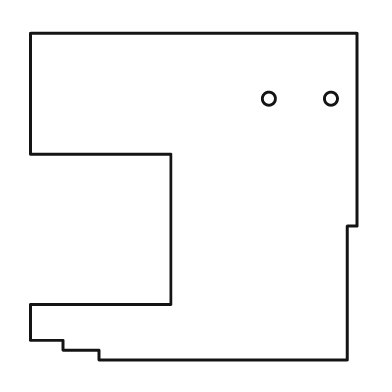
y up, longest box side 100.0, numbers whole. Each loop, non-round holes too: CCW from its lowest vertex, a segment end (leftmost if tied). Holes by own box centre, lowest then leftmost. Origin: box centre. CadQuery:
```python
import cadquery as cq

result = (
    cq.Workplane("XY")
    .moveTo(-29.0, -50.0)
    .lineTo(47.0, -50.0)
    .lineTo(47.0, -9.0)
    .lineTo(50.0, -9.0)
    .lineTo(50.0, 50.0)
    .lineTo(-50.0, 50.0)
    .lineTo(-50.0, 13.0)
    .lineTo(-7.0, 13.0)
    .lineTo(-7.0, -33.0)
    .lineTo(-50.0, -33.0)
    .lineTo(-50.0, -44.0)
    .lineTo(-40.0, -44.0)
    .lineTo(-40.0, -47.0)
    .lineTo(-29.0, -47.0)
    .close()
    .moveTo(23.0, 30.0)
    .circle(2.0)
    .moveTo(42.0, 30.0)
    .circle(2.0)
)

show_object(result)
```